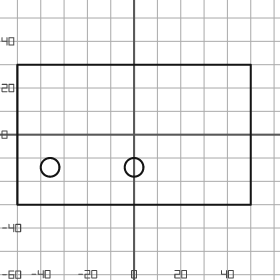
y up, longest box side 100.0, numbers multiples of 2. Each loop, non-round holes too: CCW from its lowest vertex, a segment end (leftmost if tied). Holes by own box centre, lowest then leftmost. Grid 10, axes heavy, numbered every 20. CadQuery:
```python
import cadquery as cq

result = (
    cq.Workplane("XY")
    .moveTo(-50.0, -30.0)
    .lineTo(50.0, -30.0)
    .lineTo(50.0, 30.0)
    .lineTo(-50.0, 30.0)
    .close()
    .moveTo(-36.0, -14.0)
    .circle(4.0)
    .moveTo(0.0, -14.0)
    .circle(4.0)
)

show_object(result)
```